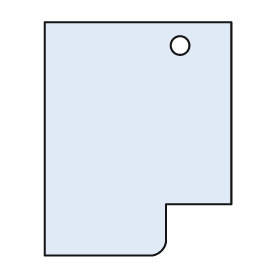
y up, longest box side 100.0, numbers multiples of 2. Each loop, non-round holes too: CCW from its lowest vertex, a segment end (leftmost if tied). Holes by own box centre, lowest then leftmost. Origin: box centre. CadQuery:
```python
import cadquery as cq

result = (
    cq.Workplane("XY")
    .moveTo(-40.0, -50.0)
    .lineTo(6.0, -50.0)
    .threePointArc((10.0, -48.0), (12.0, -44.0))
    .lineTo(12.0, -28.0)
    .lineTo(40.0, -28.0)
    .lineTo(40.0, 50.0)
    .lineTo(-40.0, 50.0)
    .close()
    .moveTo(18.0, 40.0)
    .circle(4.0)
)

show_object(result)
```